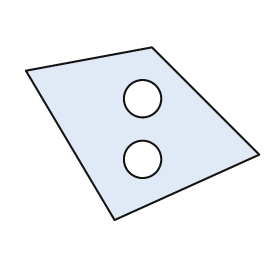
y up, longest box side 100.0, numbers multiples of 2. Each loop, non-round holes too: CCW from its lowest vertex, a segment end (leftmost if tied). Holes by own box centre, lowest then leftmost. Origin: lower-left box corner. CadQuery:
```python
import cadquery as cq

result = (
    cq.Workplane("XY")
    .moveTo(38.0, 0.0)
    .lineTo(100.0, 28.0)
    .lineTo(54.0, 74.0)
    .lineTo(0.0, 64.0)
    .close()
    .moveTo(50.0, 26.0)
    .circle(8.0)
    .moveTo(50.0, 52.0)
    .circle(8.0)
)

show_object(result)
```